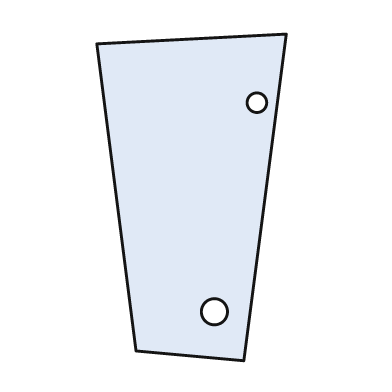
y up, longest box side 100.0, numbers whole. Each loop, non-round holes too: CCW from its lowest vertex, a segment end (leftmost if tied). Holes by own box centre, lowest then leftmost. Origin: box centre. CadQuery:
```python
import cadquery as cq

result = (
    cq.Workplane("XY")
    .moveTo(16.0, -50.0)
    .lineTo(29.0, 50.0)
    .lineTo(-29.0, 47.0)
    .lineTo(-17.0, -47.0)
    .close()
    .moveTo(7.0, -35.0)
    .circle(4.0)
    .moveTo(20.0, 29.0)
    .circle(3.0)
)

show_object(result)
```